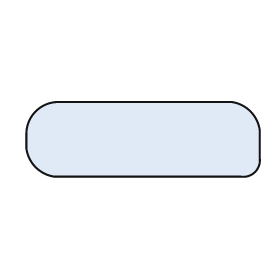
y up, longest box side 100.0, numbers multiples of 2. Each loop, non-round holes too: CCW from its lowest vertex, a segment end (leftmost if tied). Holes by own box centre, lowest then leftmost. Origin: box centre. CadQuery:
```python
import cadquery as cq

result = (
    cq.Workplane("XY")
    .moveTo(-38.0, -16.0)
    .lineTo(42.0, -16.0)
    .threePointArc((48.0, -14.0), (50.0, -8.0))
    .lineTo(50.0, 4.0)
    .threePointArc((46.0, 12.0), (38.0, 16.0))
    .lineTo(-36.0, 16.0)
    .threePointArc((-46.0, 12.0), (-50.0, 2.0))
    .lineTo(-50.0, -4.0)
    .threePointArc((-46.0, -12.0), (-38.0, -16.0))
    .close()
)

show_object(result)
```